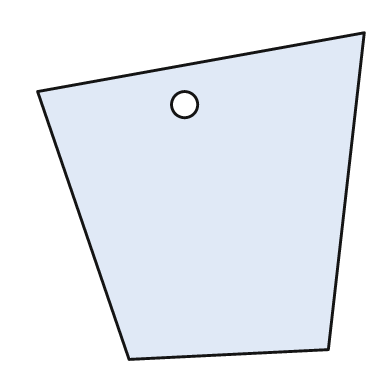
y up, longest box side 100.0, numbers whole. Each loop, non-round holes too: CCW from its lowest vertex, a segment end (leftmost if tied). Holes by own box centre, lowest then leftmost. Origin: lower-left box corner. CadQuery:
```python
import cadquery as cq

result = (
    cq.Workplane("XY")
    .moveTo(28.0, 0.0)
    .lineTo(89.0, 3.0)
    .lineTo(100.0, 100.0)
    .lineTo(0.0, 82.0)
    .close()
    .moveTo(45.0, 78.0)
    .circle(4.0)
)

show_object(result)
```